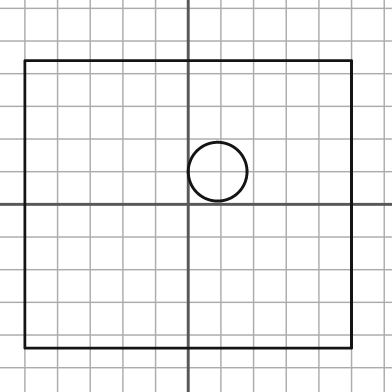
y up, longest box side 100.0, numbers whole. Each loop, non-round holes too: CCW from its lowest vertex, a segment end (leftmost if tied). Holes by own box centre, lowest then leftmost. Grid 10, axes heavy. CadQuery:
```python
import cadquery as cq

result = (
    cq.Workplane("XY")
    .moveTo(-50.0, -44.0)
    .lineTo(50.0, -44.0)
    .lineTo(50.0, 44.0)
    .lineTo(-50.0, 44.0)
    .close()
    .moveTo(9.0, 10.0)
    .circle(9.0)
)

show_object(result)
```